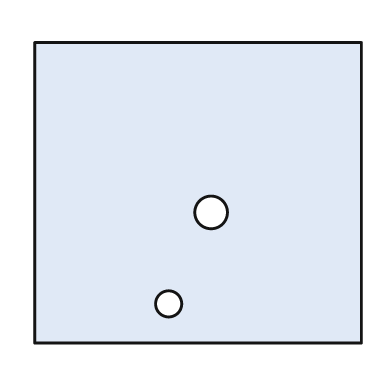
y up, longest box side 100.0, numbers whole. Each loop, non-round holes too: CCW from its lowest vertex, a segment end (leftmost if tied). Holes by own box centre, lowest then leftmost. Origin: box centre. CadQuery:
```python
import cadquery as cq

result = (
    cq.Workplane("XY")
    .moveTo(-50.0, -46.0)
    .lineTo(50.0, -46.0)
    .lineTo(50.0, 46.0)
    .lineTo(-50.0, 46.0)
    .close()
    .moveTo(-9.0, -34.0)
    .circle(4.0)
    .moveTo(4.0, -6.0)
    .circle(5.0)
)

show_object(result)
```